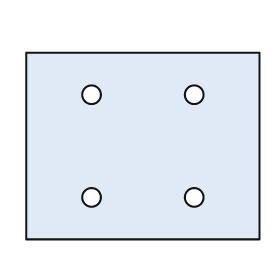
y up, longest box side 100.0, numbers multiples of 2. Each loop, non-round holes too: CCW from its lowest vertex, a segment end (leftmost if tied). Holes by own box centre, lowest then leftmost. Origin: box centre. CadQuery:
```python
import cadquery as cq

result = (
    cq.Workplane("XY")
    .moveTo(-50.0, -40.0)
    .lineTo(50.0, -40.0)
    .lineTo(50.0, 40.0)
    .lineTo(-50.0, 40.0)
    .close()
    .moveTo(-22.0, -22.0)
    .circle(4.0)
    .moveTo(22.0, -22.0)
    .circle(4.0)
    .moveTo(-22.0, 22.0)
    .circle(4.0)
    .moveTo(22.0, 22.0)
    .circle(4.0)
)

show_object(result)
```